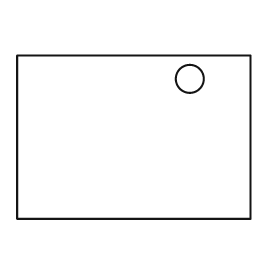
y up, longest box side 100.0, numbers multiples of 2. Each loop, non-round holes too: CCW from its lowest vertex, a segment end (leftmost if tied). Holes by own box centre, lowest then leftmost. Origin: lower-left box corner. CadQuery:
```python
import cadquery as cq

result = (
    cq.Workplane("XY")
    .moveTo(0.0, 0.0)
    .lineTo(100.0, 0.0)
    .lineTo(100.0, 70.0)
    .lineTo(0.0, 70.0)
    .close()
    .moveTo(74.0, 60.0)
    .circle(6.0)
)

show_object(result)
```